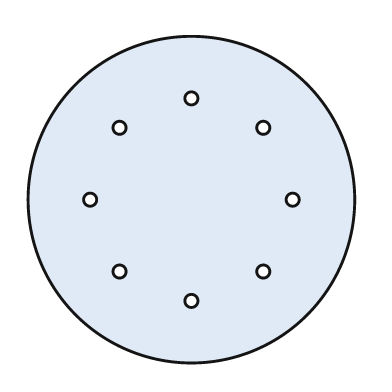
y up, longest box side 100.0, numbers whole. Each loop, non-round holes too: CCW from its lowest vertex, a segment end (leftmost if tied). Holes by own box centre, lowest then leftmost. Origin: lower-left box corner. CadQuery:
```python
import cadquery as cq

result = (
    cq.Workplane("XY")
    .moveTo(50.0, 50.0)
    .circle(50.0)
    .moveTo(50.0, 19.0)
    .circle(2.0)
    .moveTo(28.0, 28.0)
    .circle(2.0)
    .moveTo(72.0, 28.0)
    .circle(2.0)
    .moveTo(19.0, 50.0)
    .circle(2.0)
    .moveTo(81.0, 50.0)
    .circle(2.0)
    .moveTo(28.0, 72.0)
    .circle(2.0)
    .moveTo(72.0, 72.0)
    .circle(2.0)
    .moveTo(50.0, 81.0)
    .circle(2.0)
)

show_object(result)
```